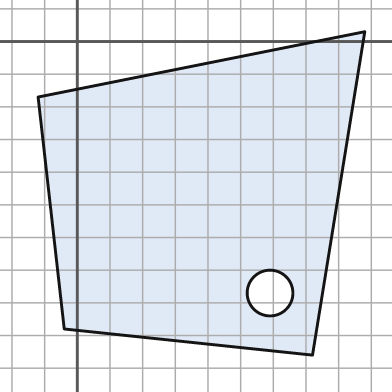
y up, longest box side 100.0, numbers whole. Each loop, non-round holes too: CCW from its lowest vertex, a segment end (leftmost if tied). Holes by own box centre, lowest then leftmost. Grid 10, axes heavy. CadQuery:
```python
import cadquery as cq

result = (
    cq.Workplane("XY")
    .moveTo(72.0, -96.0)
    .lineTo(88.0, 3.0)
    .lineTo(-12.0, -17.0)
    .lineTo(-4.0, -88.0)
    .close()
    .moveTo(59.0, -77.0)
    .circle(7.0)
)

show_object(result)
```